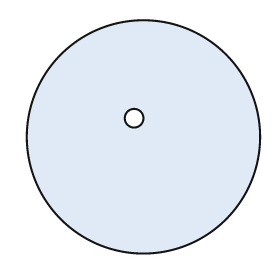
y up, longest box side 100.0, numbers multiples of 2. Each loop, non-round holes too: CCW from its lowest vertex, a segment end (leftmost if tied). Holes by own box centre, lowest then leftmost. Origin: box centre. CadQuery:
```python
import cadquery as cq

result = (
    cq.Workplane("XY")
    .moveTo(0.0, 0.0)
    .circle(50.0)
    .moveTo(-4.0, 8.0)
    .circle(4.0)
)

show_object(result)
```